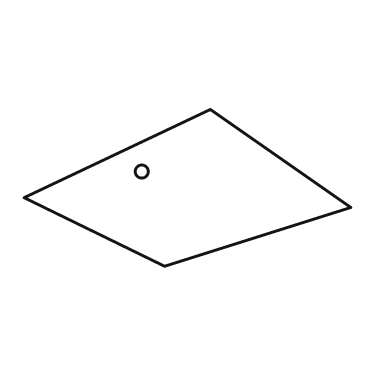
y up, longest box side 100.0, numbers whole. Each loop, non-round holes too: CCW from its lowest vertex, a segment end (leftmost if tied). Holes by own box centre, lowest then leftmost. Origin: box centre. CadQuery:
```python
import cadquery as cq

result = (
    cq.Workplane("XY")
    .moveTo(-7.0, -24.0)
    .lineTo(50.0, -6.0)
    .lineTo(7.0, 24.0)
    .lineTo(-50.0, -3.0)
    .close()
    .moveTo(-14.0, 5.0)
    .circle(2.0)
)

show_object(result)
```